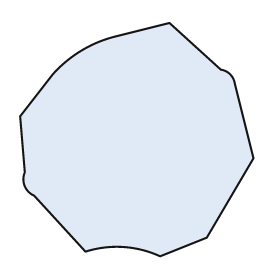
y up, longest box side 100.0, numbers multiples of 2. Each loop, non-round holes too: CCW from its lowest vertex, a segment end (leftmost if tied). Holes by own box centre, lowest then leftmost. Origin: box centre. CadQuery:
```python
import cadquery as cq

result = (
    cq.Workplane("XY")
    .moveTo(10.0, -50.0)
    .lineTo(30.0, -42.0)
    .lineTo(50.0, -8.0)
    .lineTo(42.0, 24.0)
    .threePointArc((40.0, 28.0), (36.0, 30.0))
    .lineTo(14.0, 50.0)
    .lineTo(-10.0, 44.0)
    .threePointArc((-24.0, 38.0), (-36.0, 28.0))
    .lineTo(-50.0, 10.0)
    .lineTo(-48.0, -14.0)
    .threePointArc((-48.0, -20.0), (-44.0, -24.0))
    .lineTo(-22.0, -48.0)
    .threePointArc((-6.0, -46.0), (10.0, -50.0))
    .close()
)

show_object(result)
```